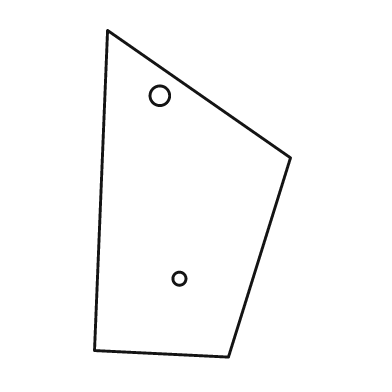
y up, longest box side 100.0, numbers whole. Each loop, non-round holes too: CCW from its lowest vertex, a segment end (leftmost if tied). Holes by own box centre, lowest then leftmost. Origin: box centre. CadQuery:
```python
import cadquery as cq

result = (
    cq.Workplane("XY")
    .moveTo(11.0, -50.0)
    .lineTo(30.0, 11.0)
    .lineTo(-26.0, 50.0)
    .lineTo(-30.0, -48.0)
    .close()
    .moveTo(-4.0, -26.0)
    .circle(2.0)
    .moveTo(-10.0, 30.0)
    .circle(3.0)
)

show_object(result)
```